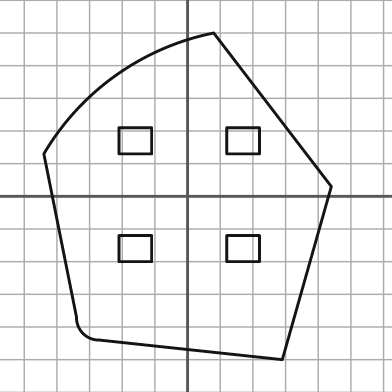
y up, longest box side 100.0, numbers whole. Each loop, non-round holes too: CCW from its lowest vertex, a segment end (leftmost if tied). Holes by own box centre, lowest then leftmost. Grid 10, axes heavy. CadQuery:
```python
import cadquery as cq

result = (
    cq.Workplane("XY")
    .moveTo(29.0, -50.0)
    .lineTo(44.0, 3.0)
    .lineTo(8.0, 50.0)
    .threePointArc((-22.0, 37.0), (-44.0, 13.0))
    .lineTo(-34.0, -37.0)
    .threePointArc((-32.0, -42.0), (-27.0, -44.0))
    .close()
    .moveTo(-21.0, -20.0)
    .lineTo(-11.0, -20.0)
    .lineTo(-11.0, -12.0)
    .lineTo(-21.0, -12.0)
    .close()
    .moveTo(12.0, -20.0)
    .lineTo(22.0, -20.0)
    .lineTo(22.0, -12.0)
    .lineTo(12.0, -12.0)
    .close()
    .moveTo(-21.0, 13.0)
    .lineTo(-11.0, 13.0)
    .lineTo(-11.0, 21.0)
    .lineTo(-21.0, 21.0)
    .close()
    .moveTo(12.0, 13.0)
    .lineTo(22.0, 13.0)
    .lineTo(22.0, 21.0)
    .lineTo(12.0, 21.0)
    .close()
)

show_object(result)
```